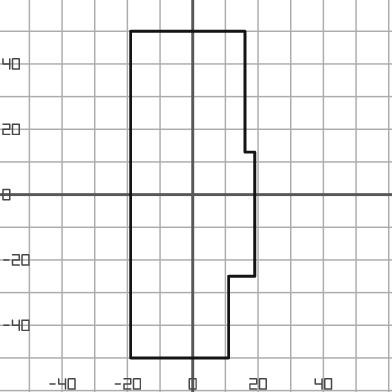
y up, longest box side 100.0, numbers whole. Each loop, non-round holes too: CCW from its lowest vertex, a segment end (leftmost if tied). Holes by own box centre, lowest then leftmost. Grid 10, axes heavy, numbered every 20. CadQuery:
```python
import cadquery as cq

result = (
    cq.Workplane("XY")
    .moveTo(-19.0, -50.0)
    .lineTo(11.0, -50.0)
    .lineTo(11.0, -25.0)
    .lineTo(19.0, -25.0)
    .lineTo(19.0, 13.0)
    .lineTo(16.0, 13.0)
    .lineTo(16.0, 50.0)
    .lineTo(-19.0, 50.0)
    .close()
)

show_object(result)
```